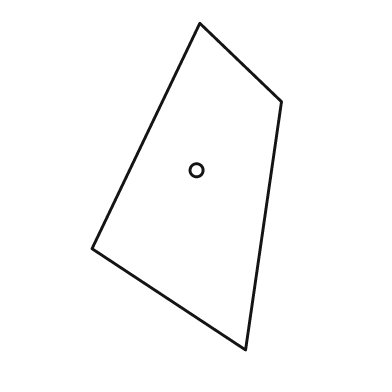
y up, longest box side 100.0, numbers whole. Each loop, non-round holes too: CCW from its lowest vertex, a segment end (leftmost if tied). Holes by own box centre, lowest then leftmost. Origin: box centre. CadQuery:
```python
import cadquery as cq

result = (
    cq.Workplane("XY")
    .moveTo(18.0, -50.0)
    .lineTo(29.0, 26.0)
    .lineTo(4.0, 50.0)
    .lineTo(-29.0, -19.0)
    .close()
    .moveTo(3.0, 5.0)
    .circle(2.0)
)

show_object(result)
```